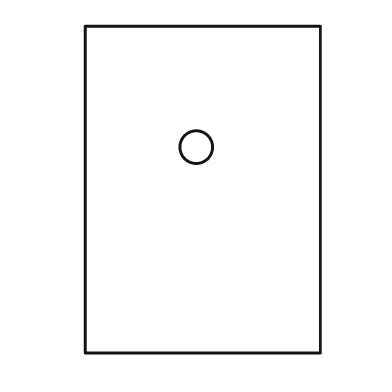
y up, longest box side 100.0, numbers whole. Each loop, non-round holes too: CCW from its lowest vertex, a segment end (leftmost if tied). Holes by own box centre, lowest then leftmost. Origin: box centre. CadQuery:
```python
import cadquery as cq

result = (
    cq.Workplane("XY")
    .moveTo(-36.0, -50.0)
    .lineTo(36.0, -50.0)
    .lineTo(36.0, 50.0)
    .lineTo(-36.0, 50.0)
    .close()
    .moveTo(-2.0, 13.0)
    .circle(5.0)
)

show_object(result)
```